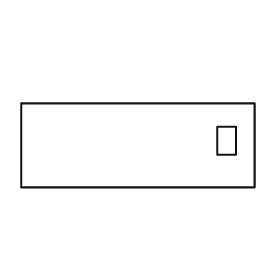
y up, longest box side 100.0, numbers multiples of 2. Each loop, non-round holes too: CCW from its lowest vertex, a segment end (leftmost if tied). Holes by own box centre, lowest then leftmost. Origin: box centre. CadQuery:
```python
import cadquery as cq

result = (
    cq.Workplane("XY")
    .moveTo(-50.0, -18.0)
    .lineTo(50.0, -18.0)
    .lineTo(50.0, 18.0)
    .lineTo(-50.0, 18.0)
    .close()
    .moveTo(34.0, -4.0)
    .lineTo(42.0, -4.0)
    .lineTo(42.0, 8.0)
    .lineTo(34.0, 8.0)
    .close()
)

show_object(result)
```